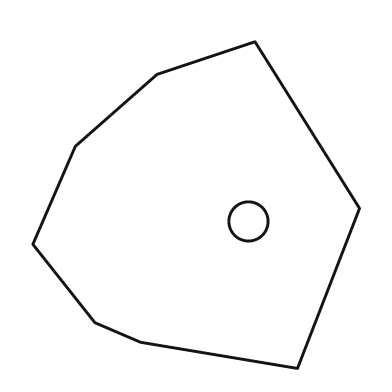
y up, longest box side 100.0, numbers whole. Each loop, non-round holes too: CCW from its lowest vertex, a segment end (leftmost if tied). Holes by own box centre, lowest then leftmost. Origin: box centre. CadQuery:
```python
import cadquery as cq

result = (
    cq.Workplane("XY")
    .moveTo(31.0, -50.0)
    .lineTo(50.0, -1.0)
    .lineTo(18.0, 50.0)
    .lineTo(-12.0, 40.0)
    .lineTo(-37.0, 18.0)
    .lineTo(-50.0, -12.0)
    .lineTo(-31.0, -36.0)
    .lineTo(-17.0, -42.0)
    .close()
    .moveTo(16.0, -5.0)
    .circle(6.0)
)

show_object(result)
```